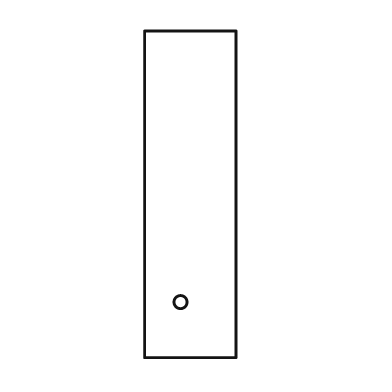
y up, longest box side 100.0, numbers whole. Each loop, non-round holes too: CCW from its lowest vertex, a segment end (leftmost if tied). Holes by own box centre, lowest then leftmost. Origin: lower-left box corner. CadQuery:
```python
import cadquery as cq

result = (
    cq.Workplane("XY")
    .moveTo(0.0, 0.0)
    .lineTo(28.0, 0.0)
    .lineTo(28.0, 100.0)
    .lineTo(0.0, 100.0)
    .close()
    .moveTo(11.0, 17.0)
    .circle(2.0)
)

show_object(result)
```